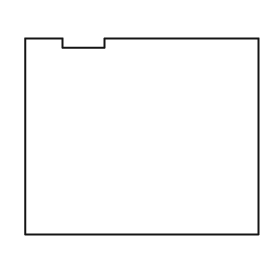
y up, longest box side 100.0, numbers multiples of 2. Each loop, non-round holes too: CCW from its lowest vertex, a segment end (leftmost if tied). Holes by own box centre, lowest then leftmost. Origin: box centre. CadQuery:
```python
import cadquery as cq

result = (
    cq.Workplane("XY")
    .moveTo(-50.0, -42.0)
    .lineTo(50.0, -42.0)
    .lineTo(50.0, 42.0)
    .lineTo(-16.0, 42.0)
    .lineTo(-16.0, 38.0)
    .lineTo(-34.0, 38.0)
    .lineTo(-34.0, 42.0)
    .lineTo(-50.0, 42.0)
    .close()
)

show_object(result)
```